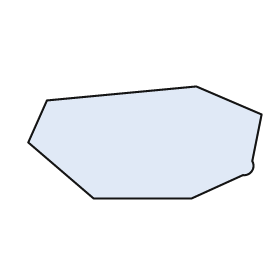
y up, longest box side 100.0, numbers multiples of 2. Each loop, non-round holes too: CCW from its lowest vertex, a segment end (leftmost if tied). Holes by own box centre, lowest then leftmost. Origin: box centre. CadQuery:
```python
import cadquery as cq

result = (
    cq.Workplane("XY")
    .moveTo(-22.0, -24.0)
    .lineTo(20.0, -24.0)
    .lineTo(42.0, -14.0)
    .threePointArc((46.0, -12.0), (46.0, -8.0))
    .lineTo(50.0, 12.0)
    .lineTo(22.0, 24.0)
    .lineTo(-42.0, 18.0)
    .lineTo(-50.0, 0.0)
    .close()
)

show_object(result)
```